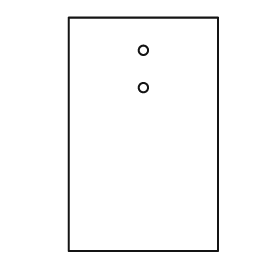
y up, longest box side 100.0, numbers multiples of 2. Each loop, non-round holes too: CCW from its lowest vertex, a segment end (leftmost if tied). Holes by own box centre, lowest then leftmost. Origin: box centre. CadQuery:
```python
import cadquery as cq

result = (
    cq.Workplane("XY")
    .moveTo(-32.0, -50.0)
    .lineTo(32.0, -50.0)
    .lineTo(32.0, 50.0)
    .lineTo(-32.0, 50.0)
    .close()
    .moveTo(0.0, 20.0)
    .circle(2.0)
    .moveTo(0.0, 36.0)
    .circle(2.0)
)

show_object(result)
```